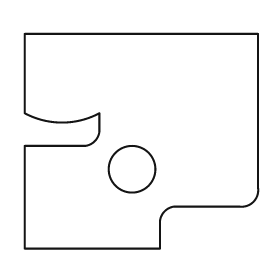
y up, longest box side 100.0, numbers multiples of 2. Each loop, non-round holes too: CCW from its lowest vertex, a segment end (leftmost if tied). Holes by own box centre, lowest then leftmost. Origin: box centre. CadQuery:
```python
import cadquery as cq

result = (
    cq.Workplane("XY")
    .moveTo(-50.0, -46.0)
    .lineTo(8.0, -46.0)
    .lineTo(8.0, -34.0)
    .threePointArc((10.0, -30.0), (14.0, -28.0))
    .lineTo(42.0, -28.0)
    .threePointArc((48.0, -26.0), (50.0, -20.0))
    .lineTo(50.0, 46.0)
    .lineTo(-50.0, 46.0)
    .lineTo(-50.0, 12.0)
    .threePointArc((-34.0, 8.0), (-18.0, 12.0))
    .lineTo(-18.0, 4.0)
    .threePointArc((-20.0, 0.0), (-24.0, -2.0))
    .lineTo(-50.0, -2.0)
    .close()
    .moveTo(-4.0, -12.0)
    .circle(10.0)
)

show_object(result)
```